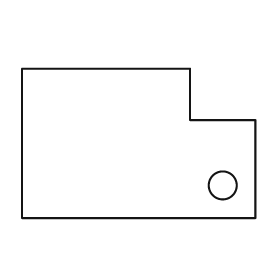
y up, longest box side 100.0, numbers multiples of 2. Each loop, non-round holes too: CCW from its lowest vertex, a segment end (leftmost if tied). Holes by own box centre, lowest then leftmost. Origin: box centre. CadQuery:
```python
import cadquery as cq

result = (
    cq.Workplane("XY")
    .moveTo(-50.0, -32.0)
    .lineTo(50.0, -32.0)
    .lineTo(50.0, 10.0)
    .lineTo(22.0, 10.0)
    .lineTo(22.0, 32.0)
    .lineTo(-50.0, 32.0)
    .close()
    .moveTo(36.0, -18.0)
    .circle(6.0)
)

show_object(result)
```